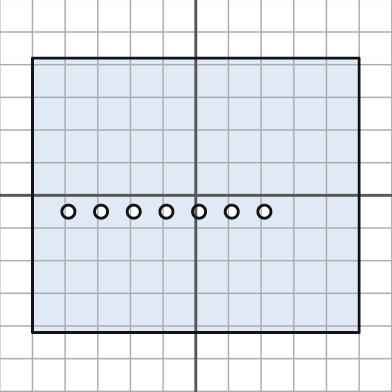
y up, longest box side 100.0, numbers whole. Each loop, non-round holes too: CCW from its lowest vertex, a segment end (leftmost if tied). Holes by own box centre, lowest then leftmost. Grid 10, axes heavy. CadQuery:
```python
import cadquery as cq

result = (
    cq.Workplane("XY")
    .moveTo(-50.0, -42.0)
    .lineTo(50.0, -42.0)
    .lineTo(50.0, 42.0)
    .lineTo(-50.0, 42.0)
    .close()
    .moveTo(-39.0, -5.0)
    .circle(2.0)
    .moveTo(-29.0, -5.0)
    .circle(2.0)
    .moveTo(-19.0, -5.0)
    .circle(2.0)
    .moveTo(-9.0, -5.0)
    .circle(2.0)
    .moveTo(1.0, -5.0)
    .circle(2.0)
    .moveTo(11.0, -5.0)
    .circle(2.0)
    .moveTo(21.0, -5.0)
    .circle(2.0)
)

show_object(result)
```